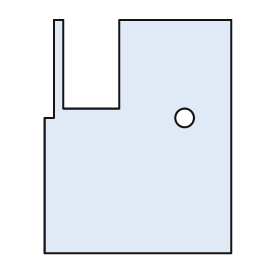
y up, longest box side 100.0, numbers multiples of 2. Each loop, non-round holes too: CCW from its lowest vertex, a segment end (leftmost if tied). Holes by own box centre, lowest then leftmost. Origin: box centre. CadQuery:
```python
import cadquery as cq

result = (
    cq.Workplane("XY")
    .moveTo(-40.0, -50.0)
    .lineTo(40.0, -50.0)
    .lineTo(40.0, 50.0)
    .lineTo(-8.0, 50.0)
    .lineTo(-8.0, 12.0)
    .lineTo(-32.0, 12.0)
    .lineTo(-32.0, 50.0)
    .lineTo(-36.0, 50.0)
    .lineTo(-36.0, 8.0)
    .lineTo(-40.0, 8.0)
    .close()
    .moveTo(20.0, 8.0)
    .circle(4.0)
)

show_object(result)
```